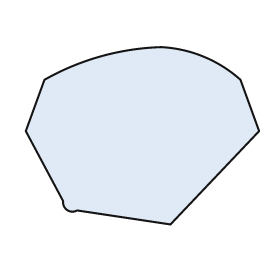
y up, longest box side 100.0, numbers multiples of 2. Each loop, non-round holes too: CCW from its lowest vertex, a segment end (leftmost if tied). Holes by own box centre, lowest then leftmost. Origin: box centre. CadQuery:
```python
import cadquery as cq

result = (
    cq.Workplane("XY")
    .moveTo(12.0, -38.0)
    .lineTo(50.0, 2.0)
    .lineTo(42.0, 24.0)
    .threePointArc((26.0, 34.0), (8.0, 38.0))
    .threePointArc((-18.0, 34.0), (-42.0, 24.0))
    .lineTo(-50.0, 2.0)
    .lineTo(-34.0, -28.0)
    .threePointArc((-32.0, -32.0), (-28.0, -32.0))
    .close()
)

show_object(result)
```